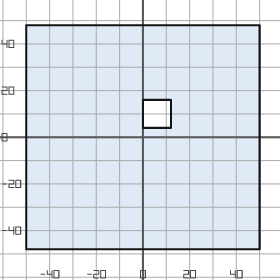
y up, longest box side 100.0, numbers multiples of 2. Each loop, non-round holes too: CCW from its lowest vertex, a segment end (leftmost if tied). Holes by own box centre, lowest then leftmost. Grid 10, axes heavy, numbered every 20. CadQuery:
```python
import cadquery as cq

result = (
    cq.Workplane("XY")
    .moveTo(-50.0, -48.0)
    .lineTo(50.0, -48.0)
    .lineTo(50.0, 48.0)
    .lineTo(-50.0, 48.0)
    .close()
    .moveTo(0.0, 4.0)
    .lineTo(12.0, 4.0)
    .lineTo(12.0, 16.0)
    .lineTo(0.0, 16.0)
    .close()
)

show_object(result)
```